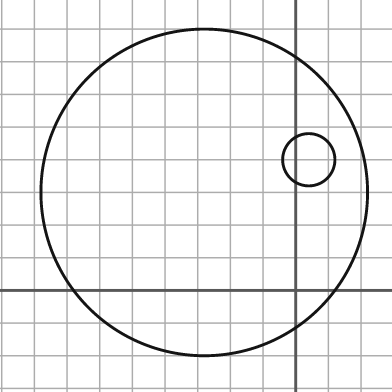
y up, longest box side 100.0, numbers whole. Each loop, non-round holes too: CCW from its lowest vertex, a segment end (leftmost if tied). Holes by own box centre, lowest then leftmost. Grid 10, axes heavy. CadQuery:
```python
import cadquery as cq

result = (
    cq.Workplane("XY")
    .moveTo(-28.0, 30.0)
    .circle(50.0)
    .moveTo(4.0, 40.0)
    .circle(8.0)
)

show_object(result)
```